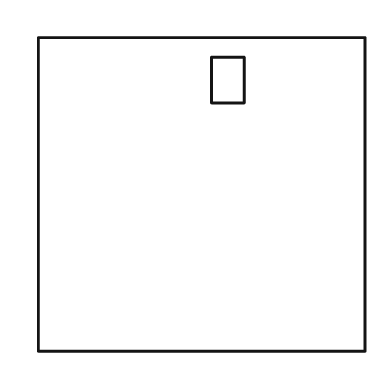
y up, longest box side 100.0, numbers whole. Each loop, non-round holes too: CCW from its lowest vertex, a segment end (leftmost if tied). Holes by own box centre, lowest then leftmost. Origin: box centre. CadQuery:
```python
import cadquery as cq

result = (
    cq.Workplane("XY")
    .moveTo(-50.0, -48.0)
    .lineTo(50.0, -48.0)
    .lineTo(50.0, 48.0)
    .lineTo(-50.0, 48.0)
    .close()
    .moveTo(3.0, 28.0)
    .lineTo(13.0, 28.0)
    .lineTo(13.0, 42.0)
    .lineTo(3.0, 42.0)
    .close()
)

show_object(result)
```